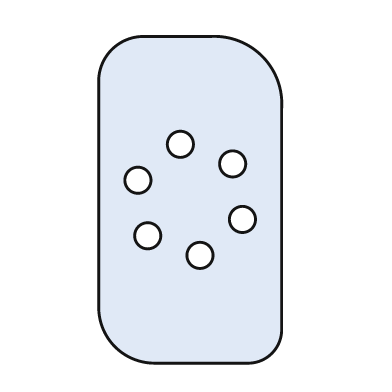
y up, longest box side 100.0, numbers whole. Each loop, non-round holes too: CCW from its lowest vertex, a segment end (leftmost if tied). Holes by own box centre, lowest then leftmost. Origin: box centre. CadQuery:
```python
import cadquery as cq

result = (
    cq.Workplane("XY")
    .moveTo(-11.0, -50.0)
    .lineTo(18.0, -50.0)
    .threePointArc((25.0, -47.0), (28.0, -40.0))
    .lineTo(28.0, 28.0)
    .threePointArc((22.0, 44.0), (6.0, 50.0))
    .lineTo(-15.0, 50.0)
    .threePointArc((-24.0, 46.0), (-28.0, 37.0))
    .lineTo(-28.0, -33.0)
    .threePointArc((-23.0, -45.0), (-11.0, -50.0))
    .close()
    .moveTo(3.0, -17.0)
    .circle(4.0)
    .moveTo(-13.0, -11.0)
    .circle(4.0)
    .moveTo(16.0, -6.0)
    .circle(4.0)
    .moveTo(-16.0, 6.0)
    .circle(4.0)
    .moveTo(13.0, 11.0)
    .circle(4.0)
    .moveTo(-3.0, 17.0)
    .circle(4.0)
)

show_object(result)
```